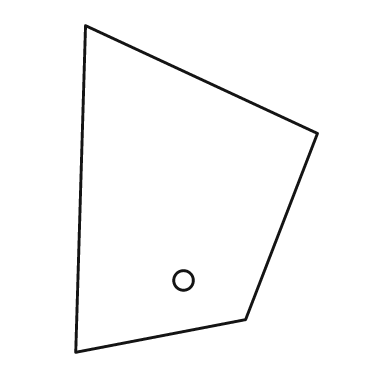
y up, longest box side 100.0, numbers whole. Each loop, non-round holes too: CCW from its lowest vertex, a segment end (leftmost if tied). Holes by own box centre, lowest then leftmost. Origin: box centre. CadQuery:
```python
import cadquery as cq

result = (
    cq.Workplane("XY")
    .moveTo(-37.0, -50.0)
    .lineTo(15.0, -40.0)
    .lineTo(37.0, 17.0)
    .lineTo(-34.0, 50.0)
    .close()
    .moveTo(-4.0, -28.0)
    .circle(3.0)
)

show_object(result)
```